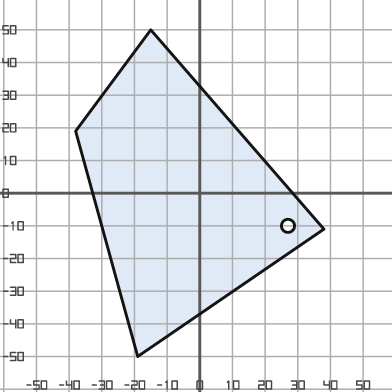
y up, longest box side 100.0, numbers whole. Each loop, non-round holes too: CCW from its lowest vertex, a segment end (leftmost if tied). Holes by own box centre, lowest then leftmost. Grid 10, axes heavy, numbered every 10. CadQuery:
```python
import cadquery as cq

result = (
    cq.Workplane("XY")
    .moveTo(-19.0, -50.0)
    .lineTo(38.0, -11.0)
    .lineTo(-15.0, 50.0)
    .lineTo(-38.0, 19.0)
    .close()
    .moveTo(27.0, -10.0)
    .circle(2.0)
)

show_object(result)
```